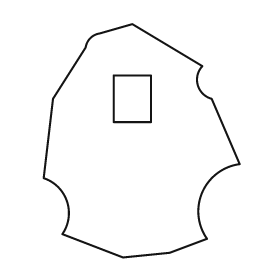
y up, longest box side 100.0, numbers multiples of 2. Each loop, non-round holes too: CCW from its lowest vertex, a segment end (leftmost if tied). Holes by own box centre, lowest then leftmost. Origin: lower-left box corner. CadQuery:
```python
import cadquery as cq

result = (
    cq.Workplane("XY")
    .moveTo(34.0, 0.0)
    .lineTo(54.0, 2.0)
    .lineTo(70.0, 8.0)
    .threePointArc((68.0, 28.0), (84.0, 40.0))
    .lineTo(72.0, 68.0)
    .threePointArc((66.0, 74.0), (68.0, 82.0))
    .lineTo(38.0, 100.0)
    .lineTo(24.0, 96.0)
    .threePointArc((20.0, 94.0), (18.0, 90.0))
    .lineTo(4.0, 68.0)
    .lineTo(0.0, 34.0)
    .threePointArc((10.0, 24.0), (8.0, 10.0))
    .close()
    .moveTo(30.0, 58.0)
    .lineTo(46.0, 58.0)
    .lineTo(46.0, 78.0)
    .lineTo(30.0, 78.0)
    .close()
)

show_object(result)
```